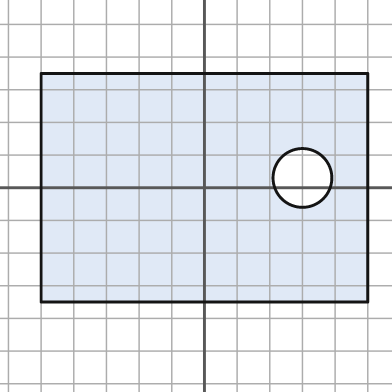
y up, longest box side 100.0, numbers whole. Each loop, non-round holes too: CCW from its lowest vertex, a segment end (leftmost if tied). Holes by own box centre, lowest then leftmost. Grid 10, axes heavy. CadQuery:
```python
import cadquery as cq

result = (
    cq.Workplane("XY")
    .moveTo(-50.0, -35.0)
    .lineTo(50.0, -35.0)
    .lineTo(50.0, 35.0)
    .lineTo(-50.0, 35.0)
    .close()
    .moveTo(30.0, 3.0)
    .circle(9.0)
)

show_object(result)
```